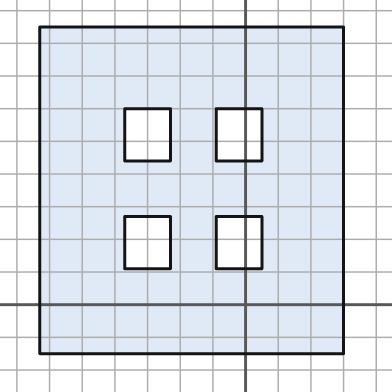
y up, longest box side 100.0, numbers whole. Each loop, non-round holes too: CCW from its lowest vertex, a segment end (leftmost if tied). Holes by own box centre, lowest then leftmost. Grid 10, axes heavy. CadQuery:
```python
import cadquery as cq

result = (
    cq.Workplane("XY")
    .moveTo(-63.0, -15.0)
    .lineTo(30.0, -15.0)
    .lineTo(30.0, 85.0)
    .lineTo(-63.0, 85.0)
    .close()
    .moveTo(-37.0, 11.0)
    .lineTo(-23.0, 11.0)
    .lineTo(-23.0, 27.0)
    .lineTo(-37.0, 27.0)
    .close()
    .moveTo(-9.0, 11.0)
    .lineTo(5.0, 11.0)
    .lineTo(5.0, 27.0)
    .lineTo(-9.0, 27.0)
    .close()
    .moveTo(-37.0, 44.0)
    .lineTo(-23.0, 44.0)
    .lineTo(-23.0, 60.0)
    .lineTo(-37.0, 60.0)
    .close()
    .moveTo(-9.0, 44.0)
    .lineTo(5.0, 44.0)
    .lineTo(5.0, 60.0)
    .lineTo(-9.0, 60.0)
    .close()
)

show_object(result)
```